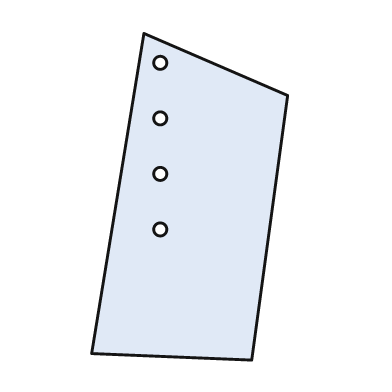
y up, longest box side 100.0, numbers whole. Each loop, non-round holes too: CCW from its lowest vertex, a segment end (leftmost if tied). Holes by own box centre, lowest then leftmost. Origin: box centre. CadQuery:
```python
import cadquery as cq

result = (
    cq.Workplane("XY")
    .moveTo(19.0, -50.0)
    .lineTo(30.0, 31.0)
    .lineTo(-14.0, 50.0)
    .lineTo(-30.0, -48.0)
    .close()
    .moveTo(-9.0, -10.0)
    .circle(2.0)
    .moveTo(-9.0, 7.0)
    .circle(2.0)
    .moveTo(-9.0, 24.0)
    .circle(2.0)
    .moveTo(-9.0, 41.0)
    .circle(2.0)
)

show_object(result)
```